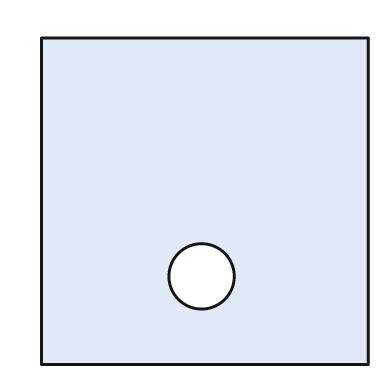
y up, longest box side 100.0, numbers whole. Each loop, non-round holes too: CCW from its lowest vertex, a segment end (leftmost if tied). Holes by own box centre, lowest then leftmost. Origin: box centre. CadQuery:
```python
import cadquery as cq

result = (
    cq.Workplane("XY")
    .moveTo(-50.0, -50.0)
    .lineTo(50.0, -50.0)
    .lineTo(50.0, 50.0)
    .lineTo(-50.0, 50.0)
    .close()
    .moveTo(-1.0, -23.0)
    .circle(10.0)
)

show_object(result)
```